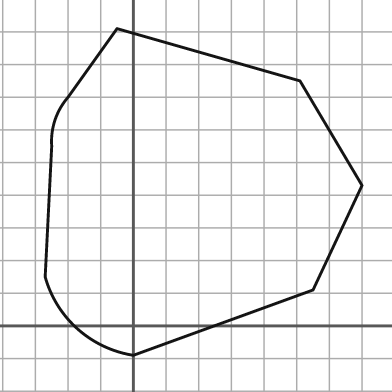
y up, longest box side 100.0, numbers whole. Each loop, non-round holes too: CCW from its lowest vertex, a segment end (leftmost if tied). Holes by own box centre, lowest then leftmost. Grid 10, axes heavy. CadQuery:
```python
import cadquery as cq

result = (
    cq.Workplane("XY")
    .moveTo(0.0, -9.0)
    .lineTo(55.0, 11.0)
    .lineTo(70.0, 43.0)
    .lineTo(51.0, 75.0)
    .lineTo(-5.0, 91.0)
    .lineTo(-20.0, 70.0)
    .threePointArc((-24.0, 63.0), (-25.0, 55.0))
    .lineTo(-27.0, 15.0)
    .threePointArc((-17.0, -1.0), (0.0, -9.0))
    .close()
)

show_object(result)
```